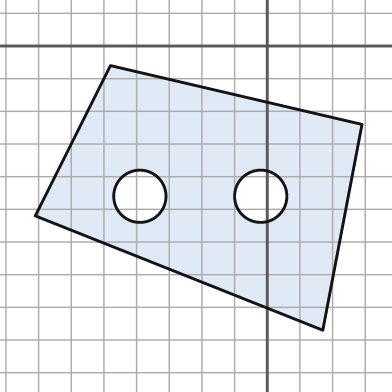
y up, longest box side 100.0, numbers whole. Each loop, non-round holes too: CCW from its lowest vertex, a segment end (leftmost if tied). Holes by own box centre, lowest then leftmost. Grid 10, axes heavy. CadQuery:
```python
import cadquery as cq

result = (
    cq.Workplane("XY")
    .moveTo(17.0, -87.0)
    .lineTo(29.0, -24.0)
    .lineTo(-48.0, -6.0)
    .lineTo(-71.0, -52.0)
    .close()
    .moveTo(-39.0, -46.0)
    .circle(8.0)
    .moveTo(-2.0, -46.0)
    .circle(8.0)
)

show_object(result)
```